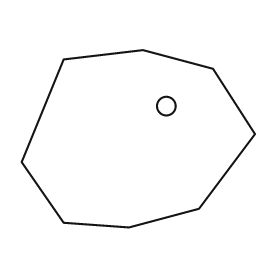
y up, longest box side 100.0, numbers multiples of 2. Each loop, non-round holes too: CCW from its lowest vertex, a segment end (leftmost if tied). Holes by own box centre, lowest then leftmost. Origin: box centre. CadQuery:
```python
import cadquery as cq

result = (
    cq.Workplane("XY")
    .moveTo(-4.0, -38.0)
    .lineTo(26.0, -30.0)
    .lineTo(50.0, 2.0)
    .lineTo(32.0, 30.0)
    .lineTo(2.0, 38.0)
    .lineTo(-32.0, 34.0)
    .lineTo(-50.0, -10.0)
    .lineTo(-32.0, -36.0)
    .close()
    .moveTo(12.0, 14.0)
    .circle(4.0)
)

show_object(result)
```